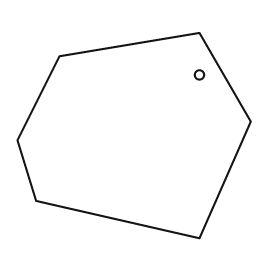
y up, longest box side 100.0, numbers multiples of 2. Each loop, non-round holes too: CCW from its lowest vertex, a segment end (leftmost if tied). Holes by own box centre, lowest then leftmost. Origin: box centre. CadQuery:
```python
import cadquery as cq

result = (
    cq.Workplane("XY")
    .moveTo(28.0, -44.0)
    .lineTo(50.0, 6.0)
    .lineTo(28.0, 44.0)
    .lineTo(-32.0, 34.0)
    .lineTo(-50.0, -2.0)
    .lineTo(-42.0, -28.0)
    .close()
    .moveTo(28.0, 26.0)
    .circle(2.0)
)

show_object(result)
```